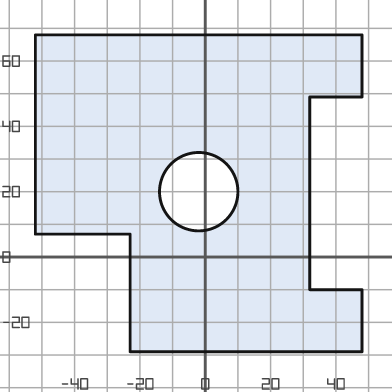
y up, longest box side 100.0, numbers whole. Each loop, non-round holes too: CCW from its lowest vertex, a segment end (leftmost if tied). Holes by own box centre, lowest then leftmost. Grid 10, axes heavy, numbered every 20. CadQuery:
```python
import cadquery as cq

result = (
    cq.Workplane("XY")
    .moveTo(-23.0, -29.0)
    .lineTo(48.0, -29.0)
    .lineTo(48.0, -10.0)
    .lineTo(32.0, -10.0)
    .lineTo(32.0, 49.0)
    .lineTo(48.0, 49.0)
    .lineTo(48.0, 68.0)
    .lineTo(-52.0, 68.0)
    .lineTo(-52.0, 7.0)
    .lineTo(-23.0, 7.0)
    .close()
    .moveTo(-2.0, 20.0)
    .circle(12.0)
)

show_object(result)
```